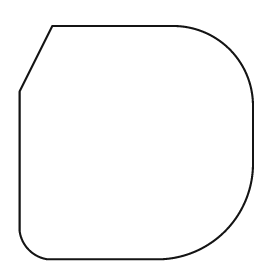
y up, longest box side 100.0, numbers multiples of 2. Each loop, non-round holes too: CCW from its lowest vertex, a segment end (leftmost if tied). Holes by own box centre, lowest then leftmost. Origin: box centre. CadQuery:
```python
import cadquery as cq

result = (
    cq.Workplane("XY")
    .moveTo(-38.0, -50.0)
    .lineTo(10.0, -50.0)
    .threePointArc((38.0, -38.0), (50.0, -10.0))
    .lineTo(50.0, 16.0)
    .threePointArc((40.0, 40.0), (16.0, 50.0))
    .lineTo(-36.0, 50.0)
    .lineTo(-50.0, 22.0)
    .lineTo(-50.0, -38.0)
    .threePointArc((-46.0, -46.0), (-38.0, -50.0))
    .close()
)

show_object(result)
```